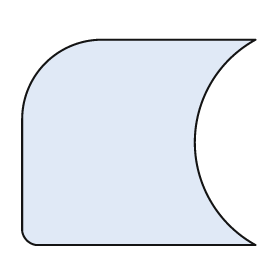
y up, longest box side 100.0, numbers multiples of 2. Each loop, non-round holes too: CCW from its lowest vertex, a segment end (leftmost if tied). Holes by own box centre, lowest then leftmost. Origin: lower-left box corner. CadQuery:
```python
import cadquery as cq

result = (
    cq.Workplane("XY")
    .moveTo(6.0, 0.0)
    .lineTo(100.0, 0.0)
    .threePointArc((74.0, 44.0), (100.0, 88.0))
    .lineTo(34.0, 88.0)
    .threePointArc((10.0, 78.0), (0.0, 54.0))
    .lineTo(0.0, 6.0)
    .threePointArc((2.0, 2.0), (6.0, 0.0))
    .close()
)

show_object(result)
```